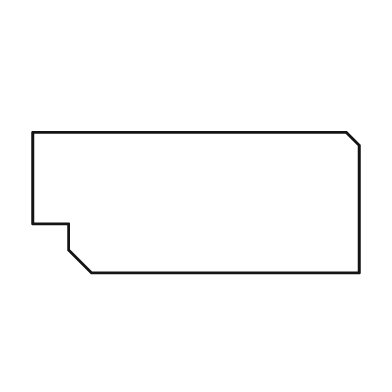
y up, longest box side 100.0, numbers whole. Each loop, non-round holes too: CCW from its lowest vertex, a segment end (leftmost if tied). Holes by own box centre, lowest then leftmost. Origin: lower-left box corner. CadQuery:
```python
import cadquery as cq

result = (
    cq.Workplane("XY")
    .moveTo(18.0, 0.0)
    .lineTo(100.0, 0.0)
    .lineTo(100.0, 39.0)
    .lineTo(96.0, 43.0)
    .lineTo(0.0, 43.0)
    .lineTo(0.0, 15.0)
    .lineTo(11.0, 15.0)
    .lineTo(11.0, 7.0)
    .close()
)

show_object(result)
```